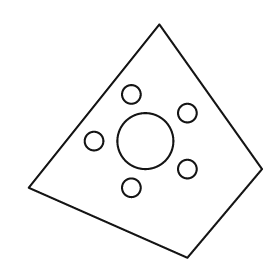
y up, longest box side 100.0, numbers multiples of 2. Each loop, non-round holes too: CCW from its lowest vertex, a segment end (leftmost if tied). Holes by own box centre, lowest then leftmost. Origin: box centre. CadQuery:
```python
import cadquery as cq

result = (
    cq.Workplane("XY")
    .moveTo(18.0, -50.0)
    .lineTo(50.0, -12.0)
    .lineTo(6.0, 50.0)
    .lineTo(-50.0, -20.0)
    .close()
    .moveTo(-6.0, -20.0)
    .circle(4.0)
    .moveTo(18.0, -12.0)
    .circle(4.0)
    .moveTo(-22.0, 0.0)
    .circle(4.0)
    .moveTo(0.0, 0.0)
    .circle(12.0)
    .moveTo(18.0, 12.0)
    .circle(4.0)
    .moveTo(-6.0, 20.0)
    .circle(4.0)
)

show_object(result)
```